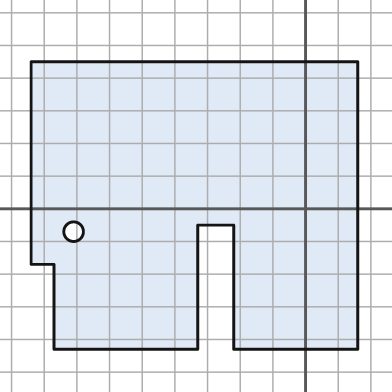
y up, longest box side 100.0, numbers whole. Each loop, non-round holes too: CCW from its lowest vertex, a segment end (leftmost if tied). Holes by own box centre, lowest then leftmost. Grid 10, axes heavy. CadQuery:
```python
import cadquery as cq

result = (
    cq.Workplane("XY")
    .moveTo(-77.0, -43.0)
    .lineTo(-33.0, -43.0)
    .lineTo(-33.0, -5.0)
    .lineTo(-22.0, -5.0)
    .lineTo(-22.0, -43.0)
    .lineTo(16.0, -43.0)
    .lineTo(16.0, 45.0)
    .lineTo(-84.0, 45.0)
    .lineTo(-84.0, -17.0)
    .lineTo(-77.0, -17.0)
    .close()
    .moveTo(-71.0, -7.0)
    .circle(3.0)
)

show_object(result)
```